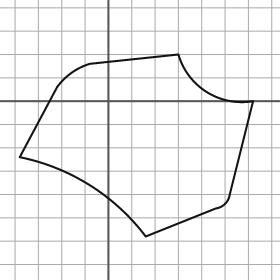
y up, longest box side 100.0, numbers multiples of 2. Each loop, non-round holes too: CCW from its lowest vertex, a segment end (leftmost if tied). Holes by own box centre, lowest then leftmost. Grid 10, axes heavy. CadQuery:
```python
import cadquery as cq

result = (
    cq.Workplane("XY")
    .moveTo(16.0, -58.0)
    .lineTo(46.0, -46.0)
    .threePointArc((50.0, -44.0), (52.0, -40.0))
    .lineTo(62.0, 0.0)
    .threePointArc((42.0, 4.0), (30.0, 20.0))
    .lineTo(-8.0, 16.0)
    .threePointArc((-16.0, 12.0), (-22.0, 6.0))
    .lineTo(-38.0, -24.0)
    .threePointArc((-8.0, -36.0), (16.0, -58.0))
    .close()
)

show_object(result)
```